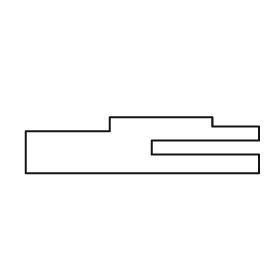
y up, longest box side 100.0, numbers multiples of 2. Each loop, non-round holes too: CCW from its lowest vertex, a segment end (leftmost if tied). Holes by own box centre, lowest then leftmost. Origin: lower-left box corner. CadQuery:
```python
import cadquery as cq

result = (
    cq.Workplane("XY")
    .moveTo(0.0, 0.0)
    .lineTo(100.0, 0.0)
    .lineTo(100.0, 8.0)
    .lineTo(54.0, 8.0)
    .lineTo(54.0, 14.0)
    .lineTo(100.0, 14.0)
    .lineTo(100.0, 20.0)
    .lineTo(80.0, 20.0)
    .lineTo(80.0, 24.0)
    .lineTo(36.0, 24.0)
    .lineTo(36.0, 18.0)
    .lineTo(0.0, 18.0)
    .close()
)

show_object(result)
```